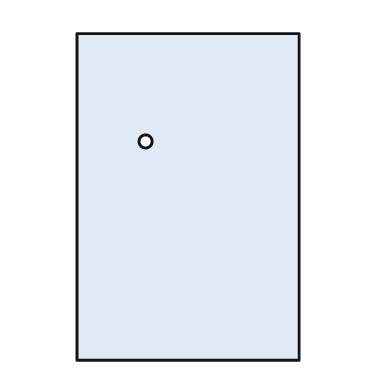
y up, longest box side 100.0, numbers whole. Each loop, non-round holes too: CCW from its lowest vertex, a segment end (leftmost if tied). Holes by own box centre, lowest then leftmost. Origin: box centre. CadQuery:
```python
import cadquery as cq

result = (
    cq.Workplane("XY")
    .moveTo(-34.0, -50.0)
    .lineTo(34.0, -50.0)
    .lineTo(34.0, 50.0)
    .lineTo(-34.0, 50.0)
    .close()
    .moveTo(-13.0, 17.0)
    .circle(2.0)
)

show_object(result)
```